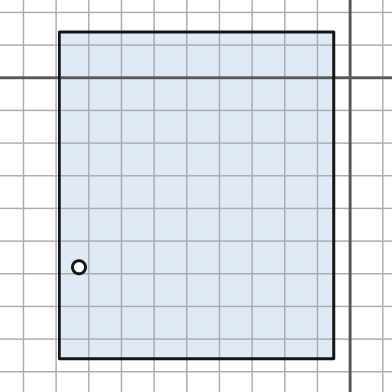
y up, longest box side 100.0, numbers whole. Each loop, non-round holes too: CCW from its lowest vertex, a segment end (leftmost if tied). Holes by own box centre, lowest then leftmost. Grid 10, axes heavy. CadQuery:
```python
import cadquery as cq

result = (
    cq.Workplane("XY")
    .moveTo(-89.0, -86.0)
    .lineTo(-5.0, -86.0)
    .lineTo(-5.0, 14.0)
    .lineTo(-89.0, 14.0)
    .close()
    .moveTo(-83.0, -58.0)
    .circle(2.0)
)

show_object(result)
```